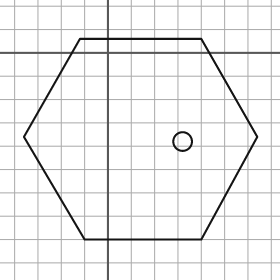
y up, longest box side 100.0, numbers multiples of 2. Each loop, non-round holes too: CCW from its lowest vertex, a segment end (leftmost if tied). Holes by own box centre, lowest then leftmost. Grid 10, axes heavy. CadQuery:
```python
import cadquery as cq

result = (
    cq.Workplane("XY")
    .moveTo(-10.0, -80.0)
    .lineTo(40.0, -80.0)
    .lineTo(64.0, -36.0)
    .lineTo(40.0, 6.0)
    .lineTo(-12.0, 6.0)
    .lineTo(-36.0, -36.0)
    .close()
    .moveTo(32.0, -38.0)
    .circle(4.0)
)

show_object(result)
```